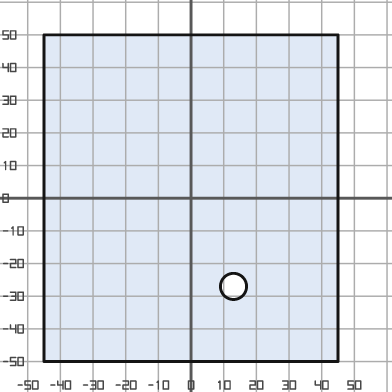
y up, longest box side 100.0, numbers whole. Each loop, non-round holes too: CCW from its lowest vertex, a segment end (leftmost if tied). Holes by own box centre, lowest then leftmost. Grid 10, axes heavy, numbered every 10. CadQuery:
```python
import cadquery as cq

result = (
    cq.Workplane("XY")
    .moveTo(-45.0, -50.0)
    .lineTo(45.0, -50.0)
    .lineTo(45.0, 50.0)
    .lineTo(-45.0, 50.0)
    .close()
    .moveTo(13.0, -27.0)
    .circle(4.0)
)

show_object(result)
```